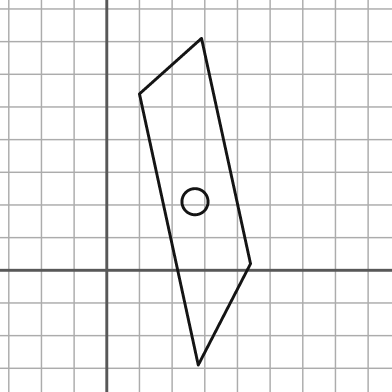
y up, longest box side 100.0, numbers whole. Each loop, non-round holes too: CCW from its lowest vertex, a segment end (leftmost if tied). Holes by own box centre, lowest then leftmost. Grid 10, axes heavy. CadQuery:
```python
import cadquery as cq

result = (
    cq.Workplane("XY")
    .moveTo(28.0, -29.0)
    .lineTo(44.0, 2.0)
    .lineTo(29.0, 71.0)
    .lineTo(10.0, 54.0)
    .close()
    .moveTo(27.0, 21.0)
    .circle(4.0)
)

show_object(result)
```